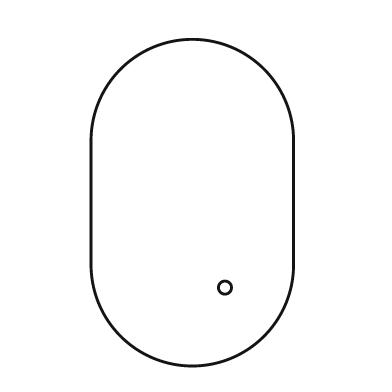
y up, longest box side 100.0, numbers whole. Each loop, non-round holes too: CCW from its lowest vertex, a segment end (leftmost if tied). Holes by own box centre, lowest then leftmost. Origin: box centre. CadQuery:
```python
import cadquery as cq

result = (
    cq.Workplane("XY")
    .moveTo(-31.0, -19.0)
    .threePointArc((0.0, -50.0), (31.0, -19.0))
    .lineTo(31.0, 19.0)
    .threePointArc((0.0, 50.0), (-31.0, 19.0))
    .close()
    .moveTo(10.0, -26.0)
    .circle(2.0)
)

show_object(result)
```